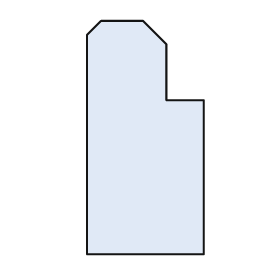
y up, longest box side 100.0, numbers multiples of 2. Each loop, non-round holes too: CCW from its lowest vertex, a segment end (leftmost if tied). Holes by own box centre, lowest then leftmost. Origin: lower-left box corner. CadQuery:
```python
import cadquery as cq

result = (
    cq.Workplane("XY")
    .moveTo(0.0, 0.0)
    .lineTo(50.0, 0.0)
    .lineTo(50.0, 66.0)
    .lineTo(34.0, 66.0)
    .lineTo(34.0, 90.0)
    .lineTo(24.0, 100.0)
    .lineTo(6.0, 100.0)
    .lineTo(0.0, 94.0)
    .close()
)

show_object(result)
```